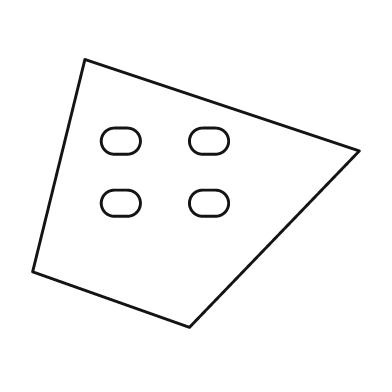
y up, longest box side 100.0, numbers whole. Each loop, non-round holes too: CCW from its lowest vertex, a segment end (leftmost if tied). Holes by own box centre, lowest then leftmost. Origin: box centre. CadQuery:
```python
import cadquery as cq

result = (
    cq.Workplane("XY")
    .moveTo(-2.0, -41.0)
    .lineTo(50.0, 13.0)
    .lineTo(-34.0, 41.0)
    .lineTo(-50.0, -24.0)
    .close()
    .moveTo(-25.0, -7.0)
    .lineTo(-21.0, -7.0)
    .threePointArc((-17.0, -3.0), (-21.0, 1.0))
    .lineTo(-25.0, 1.0)
    .threePointArc((-29.0, -3.0), (-25.0, -7.0))
    .close()
    .moveTo(2.0, -7.0)
    .lineTo(6.0, -7.0)
    .threePointArc((10.0, -3.0), (6.0, 1.0))
    .lineTo(2.0, 1.0)
    .threePointArc((-2.0, -3.0), (2.0, -7.0))
    .close()
    .moveTo(-25.0, 12.0)
    .lineTo(-21.0, 12.0)
    .threePointArc((-17.0, 16.0), (-21.0, 20.0))
    .lineTo(-25.0, 20.0)
    .threePointArc((-29.0, 16.0), (-25.0, 12.0))
    .close()
    .moveTo(2.0, 12.0)
    .lineTo(6.0, 12.0)
    .threePointArc((10.0, 16.0), (6.0, 20.0))
    .lineTo(2.0, 20.0)
    .threePointArc((-2.0, 16.0), (2.0, 12.0))
    .close()
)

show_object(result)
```